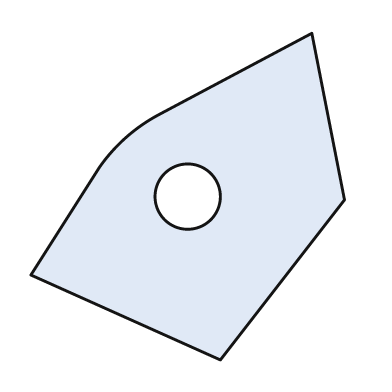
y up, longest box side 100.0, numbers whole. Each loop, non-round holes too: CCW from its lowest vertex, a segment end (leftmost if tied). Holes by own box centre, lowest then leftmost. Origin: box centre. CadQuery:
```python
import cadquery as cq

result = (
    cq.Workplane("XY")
    .moveTo(10.0, -50.0)
    .lineTo(48.0, -1.0)
    .lineTo(38.0, 50.0)
    .lineTo(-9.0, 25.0)
    .threePointArc((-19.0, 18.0), (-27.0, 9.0))
    .lineTo(-48.0, -24.0)
    .close()
    .moveTo(0.0, 0.0)
    .circle(10.0)
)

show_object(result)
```